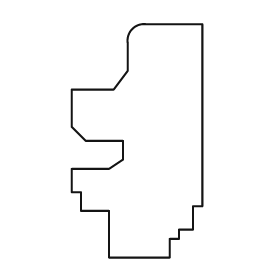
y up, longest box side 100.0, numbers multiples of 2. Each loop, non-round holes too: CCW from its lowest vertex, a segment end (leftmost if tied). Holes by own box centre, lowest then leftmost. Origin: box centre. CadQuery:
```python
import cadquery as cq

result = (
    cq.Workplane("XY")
    .moveTo(-12.0, -50.0)
    .lineTo(14.0, -50.0)
    .lineTo(14.0, -42.0)
    .lineTo(18.0, -42.0)
    .lineTo(18.0, -38.0)
    .lineTo(24.0, -38.0)
    .lineTo(24.0, -28.0)
    .lineTo(28.0, -28.0)
    .lineTo(28.0, 50.0)
    .lineTo(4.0, 50.0)
    .threePointArc((-2.0, 48.0), (-4.0, 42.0))
    .lineTo(-4.0, 30.0)
    .lineTo(-10.0, 22.0)
    .lineTo(-28.0, 22.0)
    .lineTo(-28.0, 6.0)
    .lineTo(-22.0, 0.0)
    .lineTo(-6.0, 0.0)
    .lineTo(-6.0, -8.0)
    .lineTo(-12.0, -12.0)
    .lineTo(-28.0, -12.0)
    .lineTo(-28.0, -22.0)
    .lineTo(-24.0, -22.0)
    .lineTo(-24.0, -30.0)
    .lineTo(-12.0, -30.0)
    .close()
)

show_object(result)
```